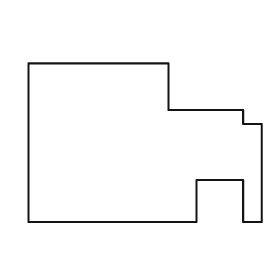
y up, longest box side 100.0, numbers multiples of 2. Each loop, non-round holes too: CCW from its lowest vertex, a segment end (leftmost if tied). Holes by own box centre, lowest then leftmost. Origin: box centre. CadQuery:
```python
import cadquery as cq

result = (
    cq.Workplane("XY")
    .moveTo(-50.0, -34.0)
    .lineTo(22.0, -34.0)
    .lineTo(22.0, -16.0)
    .lineTo(42.0, -16.0)
    .lineTo(42.0, -34.0)
    .lineTo(50.0, -34.0)
    .lineTo(50.0, 8.0)
    .lineTo(42.0, 8.0)
    .lineTo(42.0, 14.0)
    .lineTo(10.0, 14.0)
    .lineTo(10.0, 34.0)
    .lineTo(-50.0, 34.0)
    .close()
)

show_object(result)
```